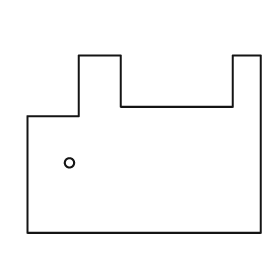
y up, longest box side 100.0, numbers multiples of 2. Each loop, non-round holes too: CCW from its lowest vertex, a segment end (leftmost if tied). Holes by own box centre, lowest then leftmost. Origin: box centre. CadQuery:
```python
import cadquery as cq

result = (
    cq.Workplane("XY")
    .moveTo(-50.0, -38.0)
    .lineTo(50.0, -38.0)
    .lineTo(50.0, 38.0)
    .lineTo(38.0, 38.0)
    .lineTo(38.0, 16.0)
    .lineTo(-10.0, 16.0)
    .lineTo(-10.0, 38.0)
    .lineTo(-28.0, 38.0)
    .lineTo(-28.0, 12.0)
    .lineTo(-50.0, 12.0)
    .close()
    .moveTo(-32.0, -8.0)
    .circle(2.0)
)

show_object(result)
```